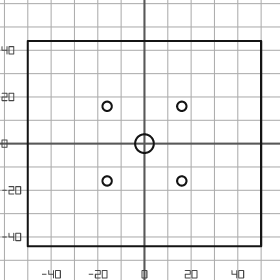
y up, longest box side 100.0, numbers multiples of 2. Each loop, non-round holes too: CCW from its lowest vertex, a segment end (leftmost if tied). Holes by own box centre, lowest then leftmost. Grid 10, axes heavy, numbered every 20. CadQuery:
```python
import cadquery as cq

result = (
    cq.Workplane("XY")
    .moveTo(-50.0, -44.0)
    .lineTo(50.0, -44.0)
    .lineTo(50.0, 44.0)
    .lineTo(-50.0, 44.0)
    .close()
    .moveTo(-16.0, -16.0)
    .circle(2.0)
    .moveTo(16.0, -16.0)
    .circle(2.0)
    .moveTo(0.0, 0.0)
    .circle(4.0)
    .moveTo(-16.0, 16.0)
    .circle(2.0)
    .moveTo(16.0, 16.0)
    .circle(2.0)
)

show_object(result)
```